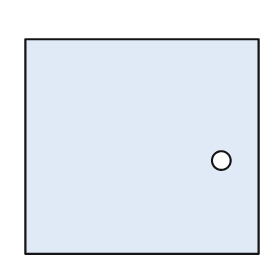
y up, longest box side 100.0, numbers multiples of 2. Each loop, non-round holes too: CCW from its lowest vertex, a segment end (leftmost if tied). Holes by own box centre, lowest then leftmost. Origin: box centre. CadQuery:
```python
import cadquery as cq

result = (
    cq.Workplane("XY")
    .moveTo(-50.0, -46.0)
    .lineTo(50.0, -46.0)
    .lineTo(50.0, 46.0)
    .lineTo(-50.0, 46.0)
    .close()
    .moveTo(34.0, -6.0)
    .circle(4.0)
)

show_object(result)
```